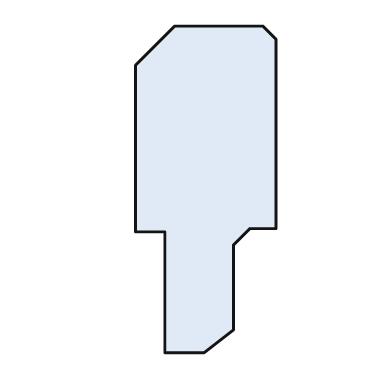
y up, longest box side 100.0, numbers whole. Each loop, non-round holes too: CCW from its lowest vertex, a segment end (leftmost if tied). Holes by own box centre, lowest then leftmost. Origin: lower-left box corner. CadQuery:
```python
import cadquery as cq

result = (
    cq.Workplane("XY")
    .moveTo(9.0, 0.0)
    .lineTo(21.0, 0.0)
    .lineTo(30.0, 7.0)
    .lineTo(30.0, 33.0)
    .lineTo(35.0, 38.0)
    .lineTo(43.0, 38.0)
    .lineTo(43.0, 96.0)
    .lineTo(39.0, 100.0)
    .lineTo(12.0, 100.0)
    .lineTo(0.0, 88.0)
    .lineTo(0.0, 37.0)
    .lineTo(9.0, 37.0)
    .close()
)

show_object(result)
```